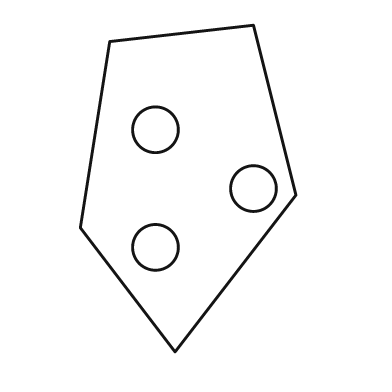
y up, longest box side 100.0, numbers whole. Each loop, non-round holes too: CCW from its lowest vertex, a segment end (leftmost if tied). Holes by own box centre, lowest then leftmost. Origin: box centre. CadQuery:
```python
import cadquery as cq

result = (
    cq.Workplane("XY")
    .moveTo(-4.0, -50.0)
    .lineTo(33.0, -2.0)
    .lineTo(20.0, 50.0)
    .lineTo(-24.0, 45.0)
    .lineTo(-33.0, -12.0)
    .close()
    .moveTo(-10.0, -18.0)
    .circle(7.0)
    .moveTo(20.0, 0.0)
    .circle(7.0)
    .moveTo(-10.0, 18.0)
    .circle(7.0)
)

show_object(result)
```